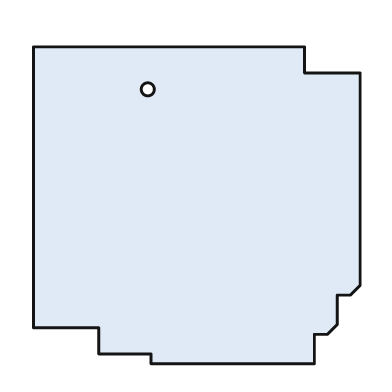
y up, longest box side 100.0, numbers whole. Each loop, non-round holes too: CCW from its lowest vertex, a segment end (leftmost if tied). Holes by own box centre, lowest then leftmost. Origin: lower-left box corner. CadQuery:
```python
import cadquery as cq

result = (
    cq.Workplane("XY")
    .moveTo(36.0, 0.0)
    .lineTo(86.0, 0.0)
    .lineTo(86.0, 9.0)
    .lineTo(90.0, 9.0)
    .lineTo(93.0, 12.0)
    .lineTo(93.0, 21.0)
    .lineTo(97.0, 21.0)
    .lineTo(100.0, 24.0)
    .lineTo(100.0, 89.0)
    .lineTo(83.0, 89.0)
    .lineTo(83.0, 97.0)
    .lineTo(0.0, 97.0)
    .lineTo(0.0, 11.0)
    .lineTo(20.0, 11.0)
    .lineTo(20.0, 3.0)
    .lineTo(36.0, 3.0)
    .close()
    .moveTo(35.0, 84.0)
    .circle(2.0)
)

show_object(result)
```